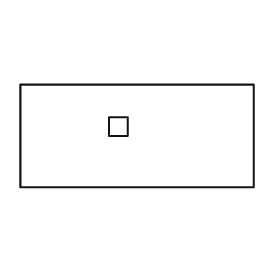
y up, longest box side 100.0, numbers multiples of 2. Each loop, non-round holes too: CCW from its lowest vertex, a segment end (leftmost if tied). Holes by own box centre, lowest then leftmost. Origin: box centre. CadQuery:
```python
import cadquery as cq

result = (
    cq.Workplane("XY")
    .moveTo(-50.0, -22.0)
    .lineTo(50.0, -22.0)
    .lineTo(50.0, 22.0)
    .lineTo(-50.0, 22.0)
    .close()
    .moveTo(-12.0, 0.0)
    .lineTo(-4.0, 0.0)
    .lineTo(-4.0, 8.0)
    .lineTo(-12.0, 8.0)
    .close()
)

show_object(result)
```